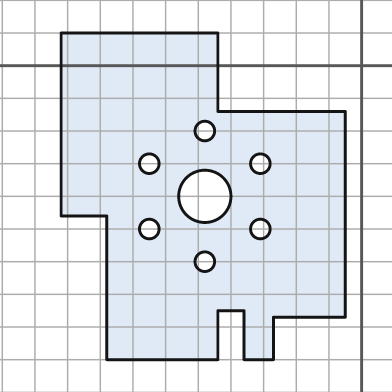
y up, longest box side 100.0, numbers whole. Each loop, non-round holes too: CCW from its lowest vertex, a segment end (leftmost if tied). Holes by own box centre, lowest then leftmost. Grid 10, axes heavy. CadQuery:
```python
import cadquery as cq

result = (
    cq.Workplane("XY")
    .moveTo(-78.0, -90.0)
    .lineTo(-44.0, -90.0)
    .lineTo(-44.0, -75.0)
    .lineTo(-36.0, -75.0)
    .lineTo(-36.0, -90.0)
    .lineTo(-27.0, -90.0)
    .lineTo(-27.0, -77.0)
    .lineTo(-5.0, -77.0)
    .lineTo(-5.0, -14.0)
    .lineTo(-44.0, -14.0)
    .lineTo(-44.0, 10.0)
    .lineTo(-92.0, 10.0)
    .lineTo(-92.0, -46.0)
    .lineTo(-78.0, -46.0)
    .close()
    .moveTo(-48.0, -60.0)
    .circle(3.0)
    .moveTo(-65.0, -50.0)
    .circle(3.0)
    .moveTo(-31.0, -50.0)
    .circle(3.0)
    .moveTo(-48.0, -40.0)
    .circle(8.0)
    .moveTo(-65.0, -30.0)
    .circle(3.0)
    .moveTo(-31.0, -30.0)
    .circle(3.0)
    .moveTo(-48.0, -20.0)
    .circle(3.0)
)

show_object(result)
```